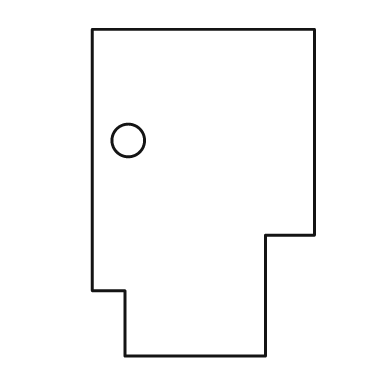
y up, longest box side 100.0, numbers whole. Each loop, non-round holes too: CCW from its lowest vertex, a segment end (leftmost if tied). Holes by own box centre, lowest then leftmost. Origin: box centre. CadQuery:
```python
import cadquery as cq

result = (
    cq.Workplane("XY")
    .moveTo(-24.0, -50.0)
    .lineTo(19.0, -50.0)
    .lineTo(19.0, -13.0)
    .lineTo(34.0, -13.0)
    .lineTo(34.0, 50.0)
    .lineTo(-34.0, 50.0)
    .lineTo(-34.0, -30.0)
    .lineTo(-24.0, -30.0)
    .close()
    .moveTo(-23.0, 16.0)
    .circle(5.0)
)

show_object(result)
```